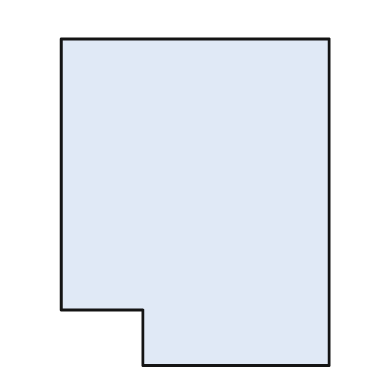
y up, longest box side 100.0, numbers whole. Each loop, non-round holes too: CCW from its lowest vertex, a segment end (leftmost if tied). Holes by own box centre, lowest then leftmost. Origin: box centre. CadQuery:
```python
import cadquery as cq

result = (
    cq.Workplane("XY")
    .moveTo(-16.0, -50.0)
    .lineTo(41.0, -50.0)
    .lineTo(41.0, 50.0)
    .lineTo(-41.0, 50.0)
    .lineTo(-41.0, -33.0)
    .lineTo(-16.0, -33.0)
    .close()
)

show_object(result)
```